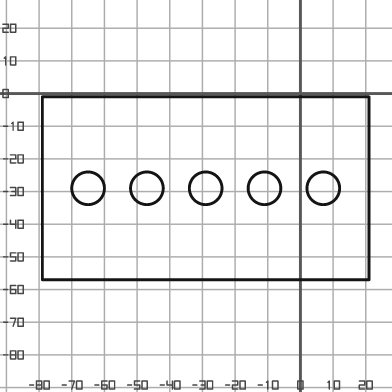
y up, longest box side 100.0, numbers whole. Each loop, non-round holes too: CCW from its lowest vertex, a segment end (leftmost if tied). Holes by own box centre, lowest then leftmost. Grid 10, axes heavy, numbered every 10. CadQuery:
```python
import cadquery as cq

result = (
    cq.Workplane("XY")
    .moveTo(-79.0, -57.0)
    .lineTo(21.0, -57.0)
    .lineTo(21.0, -1.0)
    .lineTo(-79.0, -1.0)
    .close()
    .moveTo(-65.0, -29.0)
    .circle(5.0)
    .moveTo(-47.0, -29.0)
    .circle(5.0)
    .moveTo(-29.0, -29.0)
    .circle(5.0)
    .moveTo(-11.0, -29.0)
    .circle(5.0)
    .moveTo(7.0, -29.0)
    .circle(5.0)
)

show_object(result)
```